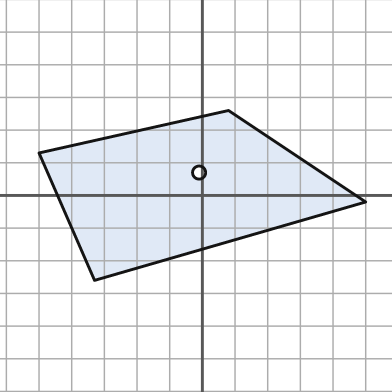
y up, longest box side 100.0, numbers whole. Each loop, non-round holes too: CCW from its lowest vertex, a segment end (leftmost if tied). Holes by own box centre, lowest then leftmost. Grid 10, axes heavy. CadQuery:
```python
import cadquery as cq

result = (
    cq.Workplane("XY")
    .moveTo(-33.0, -26.0)
    .lineTo(50.0, -2.0)
    .lineTo(8.0, 26.0)
    .lineTo(-50.0, 13.0)
    .close()
    .moveTo(-1.0, 7.0)
    .circle(2.0)
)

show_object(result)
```